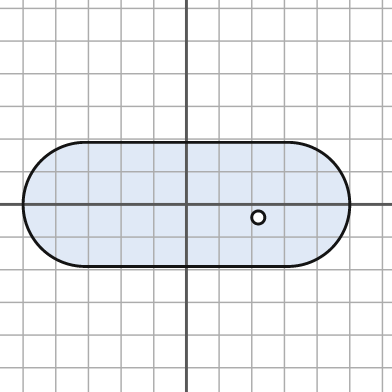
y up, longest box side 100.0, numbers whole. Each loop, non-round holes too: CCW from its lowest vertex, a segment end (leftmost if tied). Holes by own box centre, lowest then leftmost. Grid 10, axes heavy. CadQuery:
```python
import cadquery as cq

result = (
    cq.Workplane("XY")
    .moveTo(-31.0, -19.0)
    .lineTo(31.0, -19.0)
    .threePointArc((50.0, 0.0), (31.0, 19.0))
    .lineTo(-31.0, 19.0)
    .threePointArc((-50.0, 0.0), (-31.0, -19.0))
    .close()
    .moveTo(22.0, -4.0)
    .circle(2.0)
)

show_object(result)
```